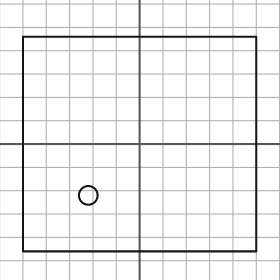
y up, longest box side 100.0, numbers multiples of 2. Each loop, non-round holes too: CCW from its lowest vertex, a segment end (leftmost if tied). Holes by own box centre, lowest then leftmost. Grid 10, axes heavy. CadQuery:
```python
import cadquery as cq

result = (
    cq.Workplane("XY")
    .moveTo(-50.0, -46.0)
    .lineTo(50.0, -46.0)
    .lineTo(50.0, 46.0)
    .lineTo(-50.0, 46.0)
    .close()
    .moveTo(-22.0, -22.0)
    .circle(4.0)
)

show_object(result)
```